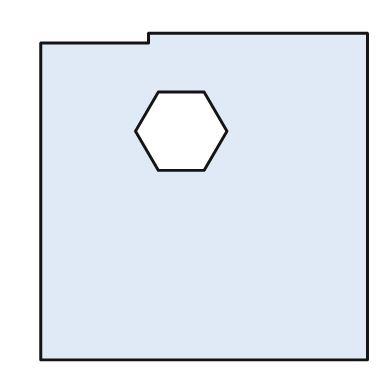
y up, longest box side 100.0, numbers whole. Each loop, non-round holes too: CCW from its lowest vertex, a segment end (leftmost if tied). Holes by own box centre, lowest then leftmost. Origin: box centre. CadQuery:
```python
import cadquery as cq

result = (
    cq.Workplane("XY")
    .moveTo(-50.0, -50.0)
    .lineTo(50.0, -50.0)
    .lineTo(50.0, 50.0)
    .lineTo(-17.0, 50.0)
    .lineTo(-17.0, 47.0)
    .lineTo(-50.0, 47.0)
    .close()
    .moveTo(-14.0, 8.0)
    .lineTo(0.0, 8.0)
    .lineTo(7.0, 20.0)
    .lineTo(0.0, 32.0)
    .lineTo(-14.0, 32.0)
    .lineTo(-21.0, 20.0)
    .close()
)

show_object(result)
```